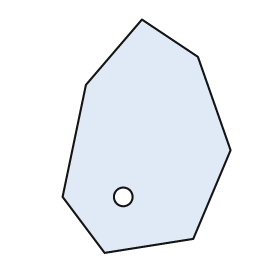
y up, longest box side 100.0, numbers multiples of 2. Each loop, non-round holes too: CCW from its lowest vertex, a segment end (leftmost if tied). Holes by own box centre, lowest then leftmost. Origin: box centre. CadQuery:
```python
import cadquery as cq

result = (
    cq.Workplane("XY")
    .moveTo(-18.0, -50.0)
    .lineTo(20.0, -44.0)
    .lineTo(36.0, -6.0)
    .lineTo(22.0, 34.0)
    .lineTo(-2.0, 50.0)
    .lineTo(-26.0, 22.0)
    .lineTo(-36.0, -26.0)
    .close()
    .moveTo(-10.0, -26.0)
    .circle(4.0)
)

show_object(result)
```